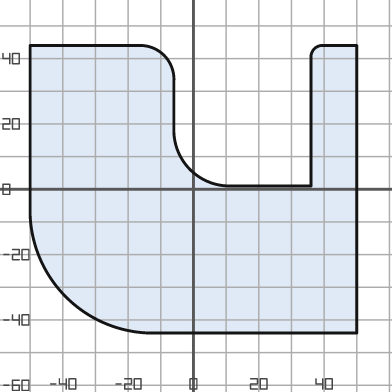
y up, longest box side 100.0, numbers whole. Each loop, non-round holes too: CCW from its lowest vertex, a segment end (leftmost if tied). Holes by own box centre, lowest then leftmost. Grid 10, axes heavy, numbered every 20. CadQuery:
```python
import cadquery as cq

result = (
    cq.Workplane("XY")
    .moveTo(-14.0, -44.0)
    .lineTo(50.0, -44.0)
    .lineTo(50.0, 44.0)
    .lineTo(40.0, 44.0)
    .threePointArc((37.0, 43.0), (36.0, 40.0))
    .lineTo(36.0, 1.0)
    .lineTo(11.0, 1.0)
    .threePointArc((-1.0, 6.0), (-6.0, 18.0))
    .lineTo(-6.0, 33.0)
    .threePointArc((-9.0, 41.0), (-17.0, 44.0))
    .lineTo(-50.0, 44.0)
    .lineTo(-50.0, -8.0)
    .threePointArc((-39.0, -33.0), (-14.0, -44.0))
    .close()
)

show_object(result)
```